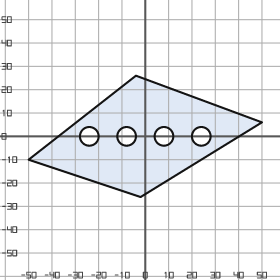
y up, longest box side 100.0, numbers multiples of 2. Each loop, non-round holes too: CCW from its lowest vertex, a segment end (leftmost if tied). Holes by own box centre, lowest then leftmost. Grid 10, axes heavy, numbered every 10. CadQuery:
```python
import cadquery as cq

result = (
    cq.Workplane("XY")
    .moveTo(-2.0, -26.0)
    .lineTo(50.0, 6.0)
    .lineTo(-4.0, 26.0)
    .lineTo(-50.0, -10.0)
    .close()
    .moveTo(-24.0, 0.0)
    .circle(4.0)
    .moveTo(-8.0, 0.0)
    .circle(4.0)
    .moveTo(8.0, 0.0)
    .circle(4.0)
    .moveTo(24.0, 0.0)
    .circle(4.0)
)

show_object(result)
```